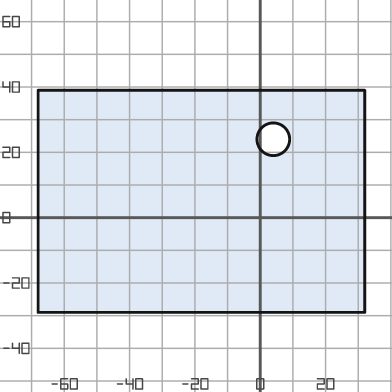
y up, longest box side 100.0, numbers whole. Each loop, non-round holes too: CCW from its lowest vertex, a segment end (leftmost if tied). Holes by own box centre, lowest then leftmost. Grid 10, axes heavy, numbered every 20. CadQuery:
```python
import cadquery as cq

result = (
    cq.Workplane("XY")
    .moveTo(-68.0, -29.0)
    .lineTo(32.0, -29.0)
    .lineTo(32.0, 39.0)
    .lineTo(-68.0, 39.0)
    .close()
    .moveTo(4.0, 24.0)
    .circle(5.0)
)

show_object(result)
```